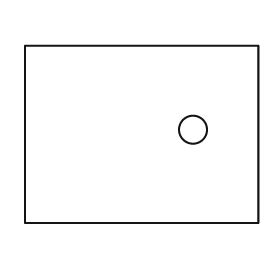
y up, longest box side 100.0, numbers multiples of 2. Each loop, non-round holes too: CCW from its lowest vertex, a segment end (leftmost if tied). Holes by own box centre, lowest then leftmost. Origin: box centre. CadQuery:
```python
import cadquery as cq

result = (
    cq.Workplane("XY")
    .moveTo(-50.0, -38.0)
    .lineTo(50.0, -38.0)
    .lineTo(50.0, 38.0)
    .lineTo(-50.0, 38.0)
    .close()
    .moveTo(22.0, 2.0)
    .circle(6.0)
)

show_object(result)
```